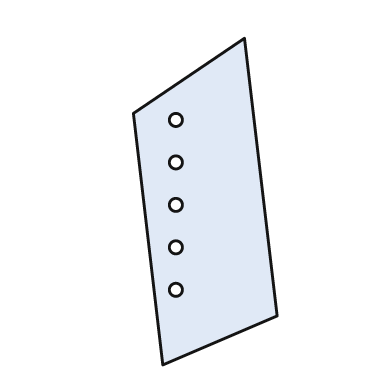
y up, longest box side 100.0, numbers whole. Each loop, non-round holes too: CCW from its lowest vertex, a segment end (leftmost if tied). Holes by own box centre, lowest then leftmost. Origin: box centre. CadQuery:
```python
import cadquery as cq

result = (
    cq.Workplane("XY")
    .moveTo(-13.0, -50.0)
    .lineTo(22.0, -35.0)
    .lineTo(12.0, 50.0)
    .lineTo(-22.0, 27.0)
    .close()
    .moveTo(-9.0, -27.0)
    .circle(2.0)
    .moveTo(-9.0, -14.0)
    .circle(2.0)
    .moveTo(-9.0, -1.0)
    .circle(2.0)
    .moveTo(-9.0, 12.0)
    .circle(2.0)
    .moveTo(-9.0, 25.0)
    .circle(2.0)
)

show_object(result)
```